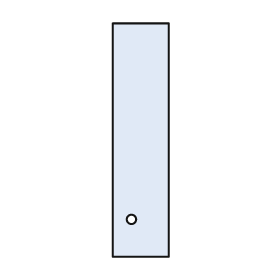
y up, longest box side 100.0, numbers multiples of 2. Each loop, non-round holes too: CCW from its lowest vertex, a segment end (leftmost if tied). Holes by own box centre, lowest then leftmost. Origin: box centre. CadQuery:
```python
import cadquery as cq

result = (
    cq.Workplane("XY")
    .moveTo(-12.0, -50.0)
    .lineTo(12.0, -50.0)
    .lineTo(12.0, 50.0)
    .lineTo(-12.0, 50.0)
    .close()
    .moveTo(-4.0, -34.0)
    .circle(2.0)
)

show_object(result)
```